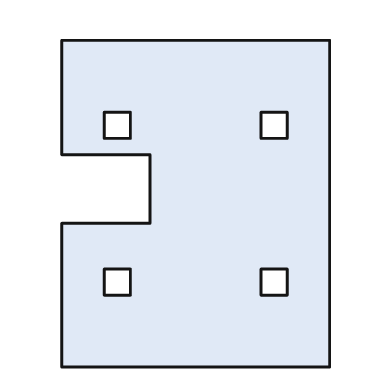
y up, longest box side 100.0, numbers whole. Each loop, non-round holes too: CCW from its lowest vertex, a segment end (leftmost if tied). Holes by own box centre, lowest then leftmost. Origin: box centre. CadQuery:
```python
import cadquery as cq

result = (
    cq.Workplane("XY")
    .moveTo(-41.0, -50.0)
    .lineTo(41.0, -50.0)
    .lineTo(41.0, 50.0)
    .lineTo(-41.0, 50.0)
    .lineTo(-41.0, 15.0)
    .lineTo(-14.0, 15.0)
    .lineTo(-14.0, -6.0)
    .lineTo(-41.0, -6.0)
    .close()
    .moveTo(-28.0, -28.0)
    .lineTo(-20.0, -28.0)
    .lineTo(-20.0, -20.0)
    .lineTo(-28.0, -20.0)
    .close()
    .moveTo(20.0, -28.0)
    .lineTo(28.0, -28.0)
    .lineTo(28.0, -20.0)
    .lineTo(20.0, -20.0)
    .close()
    .moveTo(-28.0, 20.0)
    .lineTo(-20.0, 20.0)
    .lineTo(-20.0, 28.0)
    .lineTo(-28.0, 28.0)
    .close()
    .moveTo(20.0, 20.0)
    .lineTo(28.0, 20.0)
    .lineTo(28.0, 28.0)
    .lineTo(20.0, 28.0)
    .close()
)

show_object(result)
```